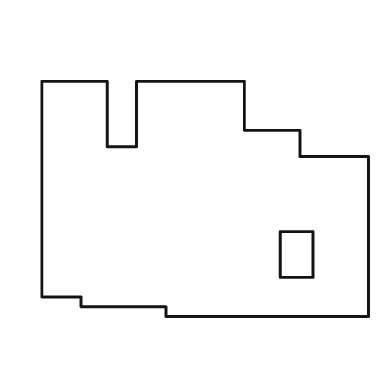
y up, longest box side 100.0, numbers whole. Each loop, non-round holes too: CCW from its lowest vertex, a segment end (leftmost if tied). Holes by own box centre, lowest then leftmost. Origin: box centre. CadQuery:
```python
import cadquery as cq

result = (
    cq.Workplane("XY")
    .moveTo(-12.0, -36.0)
    .lineTo(50.0, -36.0)
    .lineTo(50.0, 13.0)
    .lineTo(29.0, 13.0)
    .lineTo(29.0, 21.0)
    .lineTo(12.0, 21.0)
    .lineTo(12.0, 36.0)
    .lineTo(-21.0, 36.0)
    .lineTo(-21.0, 16.0)
    .lineTo(-30.0, 16.0)
    .lineTo(-30.0, 36.0)
    .lineTo(-50.0, 36.0)
    .lineTo(-50.0, -30.0)
    .lineTo(-38.0, -30.0)
    .lineTo(-38.0, -33.0)
    .lineTo(-12.0, -33.0)
    .close()
    .moveTo(23.0, -24.0)
    .lineTo(33.0, -24.0)
    .lineTo(33.0, -10.0)
    .lineTo(23.0, -10.0)
    .close()
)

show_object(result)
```